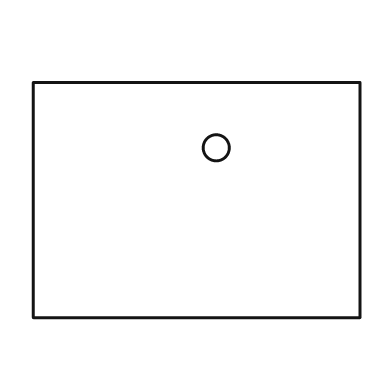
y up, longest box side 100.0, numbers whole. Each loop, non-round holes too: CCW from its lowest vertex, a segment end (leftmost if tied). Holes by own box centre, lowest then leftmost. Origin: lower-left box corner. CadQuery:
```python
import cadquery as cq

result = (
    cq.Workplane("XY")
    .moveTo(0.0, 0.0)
    .lineTo(100.0, 0.0)
    .lineTo(100.0, 72.0)
    .lineTo(0.0, 72.0)
    .close()
    .moveTo(56.0, 52.0)
    .circle(4.0)
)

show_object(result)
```